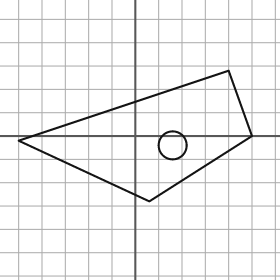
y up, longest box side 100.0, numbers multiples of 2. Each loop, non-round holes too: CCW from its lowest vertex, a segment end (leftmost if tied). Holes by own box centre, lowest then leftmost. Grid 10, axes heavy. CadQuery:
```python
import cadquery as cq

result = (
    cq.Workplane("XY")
    .moveTo(6.0, -28.0)
    .lineTo(50.0, 0.0)
    .lineTo(40.0, 28.0)
    .lineTo(-50.0, -2.0)
    .close()
    .moveTo(16.0, -4.0)
    .circle(6.0)
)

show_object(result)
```